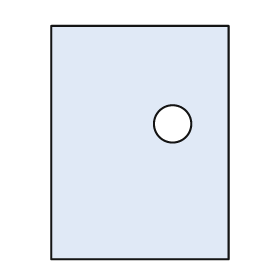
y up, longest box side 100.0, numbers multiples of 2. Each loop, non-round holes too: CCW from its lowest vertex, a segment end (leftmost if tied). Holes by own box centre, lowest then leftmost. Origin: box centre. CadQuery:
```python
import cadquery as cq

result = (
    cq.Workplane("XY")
    .moveTo(-38.0, -50.0)
    .lineTo(38.0, -50.0)
    .lineTo(38.0, 50.0)
    .lineTo(-38.0, 50.0)
    .close()
    .moveTo(14.0, 8.0)
    .circle(8.0)
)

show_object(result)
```